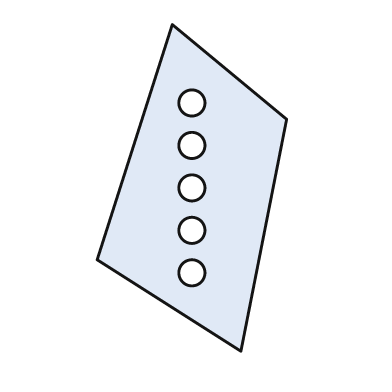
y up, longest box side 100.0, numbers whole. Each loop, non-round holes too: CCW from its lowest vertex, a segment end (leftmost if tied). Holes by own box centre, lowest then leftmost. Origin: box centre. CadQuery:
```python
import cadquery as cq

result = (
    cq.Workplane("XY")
    .moveTo(15.0, -50.0)
    .lineTo(29.0, 21.0)
    .lineTo(-6.0, 50.0)
    .lineTo(-29.0, -22.0)
    .close()
    .moveTo(0.0, -26.0)
    .circle(4.0)
    .moveTo(0.0, -13.0)
    .circle(4.0)
    .moveTo(0.0, 0.0)
    .circle(4.0)
    .moveTo(0.0, 13.0)
    .circle(4.0)
    .moveTo(0.0, 26.0)
    .circle(4.0)
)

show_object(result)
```